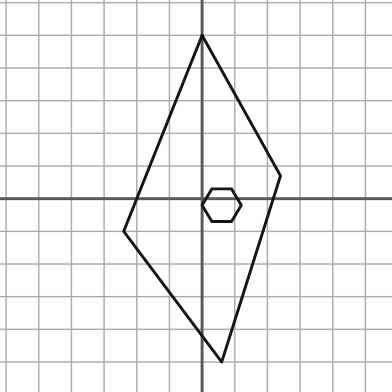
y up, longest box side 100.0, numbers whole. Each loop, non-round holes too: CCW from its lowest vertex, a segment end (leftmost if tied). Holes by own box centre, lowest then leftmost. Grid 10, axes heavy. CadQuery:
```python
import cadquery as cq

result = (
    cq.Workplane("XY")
    .moveTo(6.0, -50.0)
    .lineTo(24.0, 7.0)
    .lineTo(0.0, 50.0)
    .lineTo(-24.0, -10.0)
    .close()
    .moveTo(3.0, -7.0)
    .lineTo(9.0, -7.0)
    .lineTo(12.0, -2.0)
    .lineTo(9.0, 3.0)
    .lineTo(3.0, 3.0)
    .lineTo(0.0, -2.0)
    .close()
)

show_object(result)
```